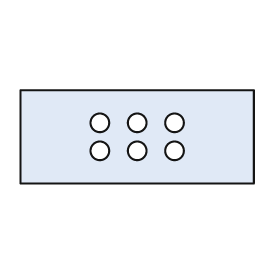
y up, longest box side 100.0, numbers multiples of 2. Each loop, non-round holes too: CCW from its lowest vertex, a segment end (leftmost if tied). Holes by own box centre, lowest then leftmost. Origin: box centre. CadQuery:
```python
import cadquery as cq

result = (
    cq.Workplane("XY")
    .moveTo(-50.0, -20.0)
    .lineTo(50.0, -20.0)
    .lineTo(50.0, 20.0)
    .lineTo(-50.0, 20.0)
    .close()
    .moveTo(-16.0, -6.0)
    .circle(4.0)
    .moveTo(0.0, -6.0)
    .circle(4.0)
    .moveTo(16.0, -6.0)
    .circle(4.0)
    .moveTo(-16.0, 6.0)
    .circle(4.0)
    .moveTo(0.0, 6.0)
    .circle(4.0)
    .moveTo(16.0, 6.0)
    .circle(4.0)
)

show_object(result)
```